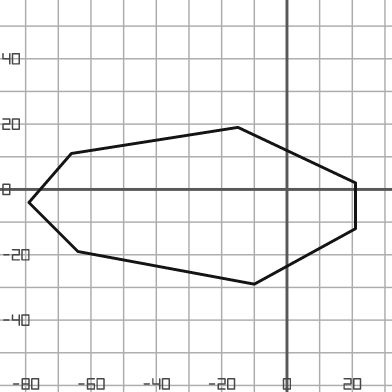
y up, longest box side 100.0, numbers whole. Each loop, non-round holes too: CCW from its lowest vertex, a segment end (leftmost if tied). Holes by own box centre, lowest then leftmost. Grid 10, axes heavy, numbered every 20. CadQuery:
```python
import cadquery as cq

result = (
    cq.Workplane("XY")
    .moveTo(-10.0, -29.0)
    .lineTo(21.0, -12.0)
    .lineTo(21.0, 2.0)
    .lineTo(-15.0, 19.0)
    .lineTo(-66.0, 11.0)
    .lineTo(-79.0, -4.0)
    .lineTo(-64.0, -19.0)
    .close()
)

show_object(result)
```